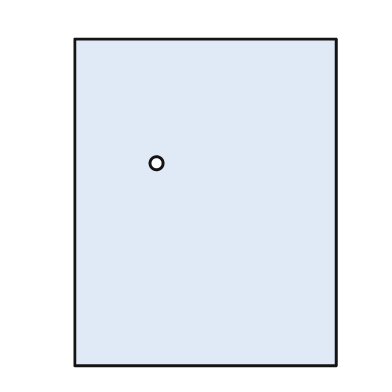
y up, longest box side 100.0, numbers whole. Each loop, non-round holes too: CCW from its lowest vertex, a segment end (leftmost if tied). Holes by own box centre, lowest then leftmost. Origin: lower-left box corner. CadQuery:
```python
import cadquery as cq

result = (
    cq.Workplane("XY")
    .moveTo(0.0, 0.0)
    .lineTo(80.0, 0.0)
    .lineTo(80.0, 100.0)
    .lineTo(0.0, 100.0)
    .close()
    .moveTo(25.0, 62.0)
    .circle(2.0)
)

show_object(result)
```